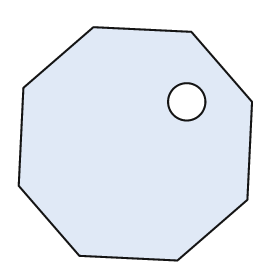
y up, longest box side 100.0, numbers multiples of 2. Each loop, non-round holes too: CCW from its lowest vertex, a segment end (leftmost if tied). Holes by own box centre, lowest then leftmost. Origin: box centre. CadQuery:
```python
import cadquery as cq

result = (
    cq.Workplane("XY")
    .moveTo(18.0, -50.0)
    .lineTo(48.0, -24.0)
    .lineTo(50.0, 18.0)
    .lineTo(24.0, 48.0)
    .lineTo(-18.0, 50.0)
    .lineTo(-48.0, 24.0)
    .lineTo(-50.0, -18.0)
    .lineTo(-24.0, -48.0)
    .close()
    .moveTo(22.0, 18.0)
    .circle(8.0)
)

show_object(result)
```